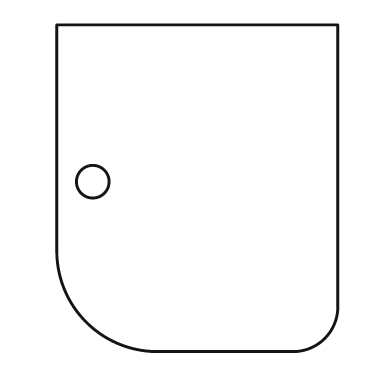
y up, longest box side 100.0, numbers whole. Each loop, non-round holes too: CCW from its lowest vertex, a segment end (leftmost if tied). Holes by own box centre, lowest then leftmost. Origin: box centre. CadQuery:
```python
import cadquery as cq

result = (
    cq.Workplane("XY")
    .moveTo(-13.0, -50.0)
    .lineTo(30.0, -50.0)
    .threePointArc((39.0, -46.0), (43.0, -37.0))
    .lineTo(43.0, 50.0)
    .lineTo(-43.0, 50.0)
    .lineTo(-43.0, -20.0)
    .threePointArc((-34.0, -41.0), (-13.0, -50.0))
    .close()
    .moveTo(-32.0, 2.0)
    .circle(5.0)
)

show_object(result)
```